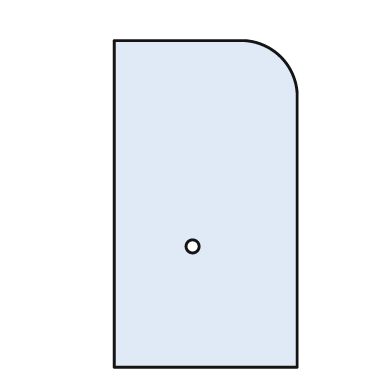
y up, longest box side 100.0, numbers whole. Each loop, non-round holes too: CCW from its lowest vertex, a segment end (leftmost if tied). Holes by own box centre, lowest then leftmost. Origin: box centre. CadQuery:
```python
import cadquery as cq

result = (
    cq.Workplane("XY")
    .moveTo(-28.0, -50.0)
    .lineTo(28.0, -50.0)
    .lineTo(28.0, 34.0)
    .threePointArc((23.0, 45.0), (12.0, 50.0))
    .lineTo(-28.0, 50.0)
    .close()
    .moveTo(-4.0, -13.0)
    .circle(2.0)
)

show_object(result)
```